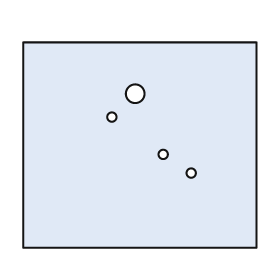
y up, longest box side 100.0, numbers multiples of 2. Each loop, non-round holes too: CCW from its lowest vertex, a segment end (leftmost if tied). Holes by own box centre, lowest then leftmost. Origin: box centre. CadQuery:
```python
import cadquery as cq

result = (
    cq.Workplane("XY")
    .moveTo(-50.0, -44.0)
    .lineTo(50.0, -44.0)
    .lineTo(50.0, 44.0)
    .lineTo(-50.0, 44.0)
    .close()
    .moveTo(22.0, -12.0)
    .circle(2.0)
    .moveTo(10.0, -4.0)
    .circle(2.0)
    .moveTo(-12.0, 12.0)
    .circle(2.0)
    .moveTo(-2.0, 22.0)
    .circle(4.0)
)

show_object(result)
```